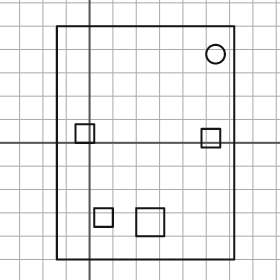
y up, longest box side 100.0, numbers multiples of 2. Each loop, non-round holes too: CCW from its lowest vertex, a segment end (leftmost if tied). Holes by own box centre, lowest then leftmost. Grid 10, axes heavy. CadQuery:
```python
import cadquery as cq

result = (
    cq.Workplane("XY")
    .moveTo(-14.0, -50.0)
    .lineTo(62.0, -50.0)
    .lineTo(62.0, 50.0)
    .lineTo(-14.0, 50.0)
    .close()
    .moveTo(20.0, -40.0)
    .lineTo(32.0, -40.0)
    .lineTo(32.0, -28.0)
    .lineTo(20.0, -28.0)
    .close()
    .moveTo(2.0, -36.0)
    .lineTo(10.0, -36.0)
    .lineTo(10.0, -28.0)
    .lineTo(2.0, -28.0)
    .close()
    .moveTo(48.0, -2.0)
    .lineTo(56.0, -2.0)
    .lineTo(56.0, 6.0)
    .lineTo(48.0, 6.0)
    .close()
    .moveTo(-6.0, 0.0)
    .lineTo(2.0, 0.0)
    .lineTo(2.0, 8.0)
    .lineTo(-6.0, 8.0)
    .close()
    .moveTo(54.0, 38.0)
    .circle(4.0)
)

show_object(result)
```